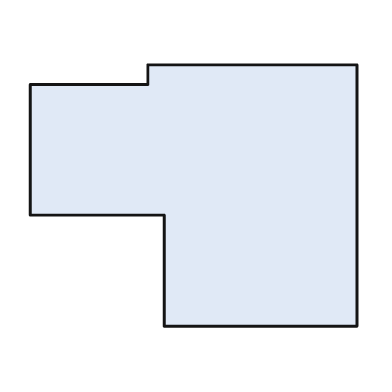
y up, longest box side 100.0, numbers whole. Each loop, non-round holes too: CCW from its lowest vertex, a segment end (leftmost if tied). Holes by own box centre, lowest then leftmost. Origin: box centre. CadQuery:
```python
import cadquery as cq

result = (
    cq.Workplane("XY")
    .moveTo(-9.0, -40.0)
    .lineTo(50.0, -40.0)
    .lineTo(50.0, 40.0)
    .lineTo(-14.0, 40.0)
    .lineTo(-14.0, 34.0)
    .lineTo(-50.0, 34.0)
    .lineTo(-50.0, -6.0)
    .lineTo(-9.0, -6.0)
    .close()
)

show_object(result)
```